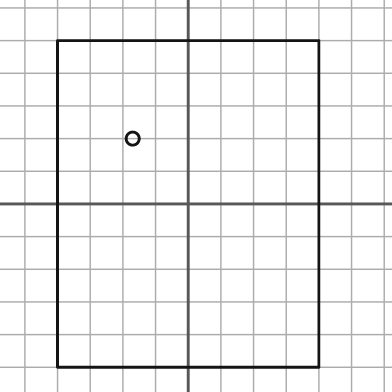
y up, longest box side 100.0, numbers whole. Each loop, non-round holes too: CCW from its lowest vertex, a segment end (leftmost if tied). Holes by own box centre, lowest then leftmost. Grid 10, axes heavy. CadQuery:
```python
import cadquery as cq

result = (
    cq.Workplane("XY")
    .moveTo(-40.0, -50.0)
    .lineTo(40.0, -50.0)
    .lineTo(40.0, 50.0)
    .lineTo(-40.0, 50.0)
    .close()
    .moveTo(-17.0, 20.0)
    .circle(2.0)
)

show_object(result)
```